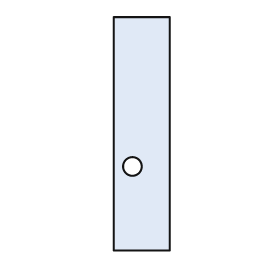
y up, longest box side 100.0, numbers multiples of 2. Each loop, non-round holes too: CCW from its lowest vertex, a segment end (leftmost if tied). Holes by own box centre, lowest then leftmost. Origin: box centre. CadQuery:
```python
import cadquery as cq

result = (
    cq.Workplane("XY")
    .moveTo(-12.0, -50.0)
    .lineTo(12.0, -50.0)
    .lineTo(12.0, 50.0)
    .lineTo(-12.0, 50.0)
    .close()
    .moveTo(-4.0, -14.0)
    .circle(4.0)
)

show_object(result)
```